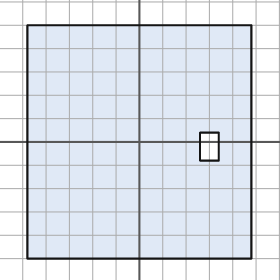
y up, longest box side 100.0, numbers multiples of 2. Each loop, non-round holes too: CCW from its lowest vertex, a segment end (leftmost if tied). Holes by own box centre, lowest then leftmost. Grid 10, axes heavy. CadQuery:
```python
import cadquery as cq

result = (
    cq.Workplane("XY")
    .moveTo(-48.0, -50.0)
    .lineTo(48.0, -50.0)
    .lineTo(48.0, 50.0)
    .lineTo(-48.0, 50.0)
    .close()
    .moveTo(26.0, -8.0)
    .lineTo(34.0, -8.0)
    .lineTo(34.0, 4.0)
    .lineTo(26.0, 4.0)
    .close()
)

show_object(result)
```